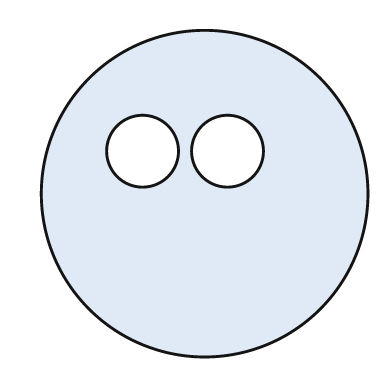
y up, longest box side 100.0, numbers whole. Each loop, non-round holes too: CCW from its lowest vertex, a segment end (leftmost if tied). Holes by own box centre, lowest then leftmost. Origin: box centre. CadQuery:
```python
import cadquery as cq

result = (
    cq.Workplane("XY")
    .moveTo(0.0, 0.0)
    .circle(50.0)
    .moveTo(-19.0, 13.0)
    .circle(11.0)
    .moveTo(7.0, 13.0)
    .circle(11.0)
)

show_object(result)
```